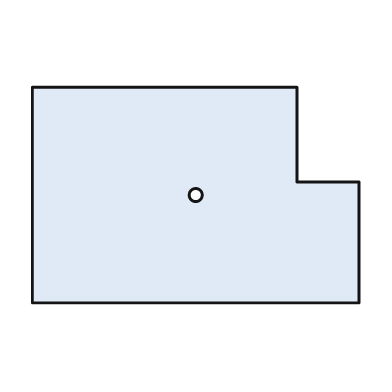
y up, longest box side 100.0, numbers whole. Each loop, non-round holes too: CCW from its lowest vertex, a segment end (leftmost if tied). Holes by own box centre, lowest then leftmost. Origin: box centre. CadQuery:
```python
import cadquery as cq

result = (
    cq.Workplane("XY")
    .moveTo(-50.0, -33.0)
    .lineTo(50.0, -33.0)
    .lineTo(50.0, 4.0)
    .lineTo(31.0, 4.0)
    .lineTo(31.0, 33.0)
    .lineTo(-50.0, 33.0)
    .close()
    .moveTo(0.0, 0.0)
    .circle(2.0)
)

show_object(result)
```